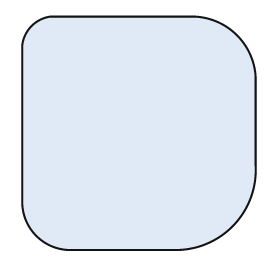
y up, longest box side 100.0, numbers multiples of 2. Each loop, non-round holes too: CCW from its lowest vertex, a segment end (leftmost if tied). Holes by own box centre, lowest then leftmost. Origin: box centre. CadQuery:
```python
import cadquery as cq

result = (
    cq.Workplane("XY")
    .moveTo(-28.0, -50.0)
    .lineTo(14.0, -50.0)
    .threePointArc((40.0, -40.0), (50.0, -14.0))
    .lineTo(50.0, 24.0)
    .threePointArc((42.0, 42.0), (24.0, 50.0))
    .lineTo(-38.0, 50.0)
    .threePointArc((-46.0, 46.0), (-50.0, 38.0))
    .lineTo(-50.0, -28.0)
    .threePointArc((-44.0, -44.0), (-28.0, -50.0))
    .close()
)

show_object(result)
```